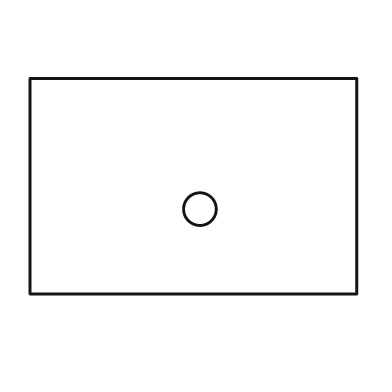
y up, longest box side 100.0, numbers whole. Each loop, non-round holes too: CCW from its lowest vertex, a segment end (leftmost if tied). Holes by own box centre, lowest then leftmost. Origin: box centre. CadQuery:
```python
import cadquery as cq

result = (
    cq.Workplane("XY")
    .moveTo(-50.0, -33.0)
    .lineTo(50.0, -33.0)
    .lineTo(50.0, 33.0)
    .lineTo(-50.0, 33.0)
    .close()
    .moveTo(2.0, -7.0)
    .circle(5.0)
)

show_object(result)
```